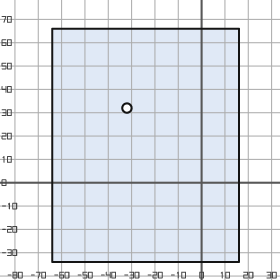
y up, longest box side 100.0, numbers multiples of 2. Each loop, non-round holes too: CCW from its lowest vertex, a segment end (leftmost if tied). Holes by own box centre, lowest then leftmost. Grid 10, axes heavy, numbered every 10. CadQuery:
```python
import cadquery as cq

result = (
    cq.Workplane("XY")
    .moveTo(-64.0, -34.0)
    .lineTo(16.0, -34.0)
    .lineTo(16.0, 66.0)
    .lineTo(-64.0, 66.0)
    .close()
    .moveTo(-32.0, 32.0)
    .circle(2.0)
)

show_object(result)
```